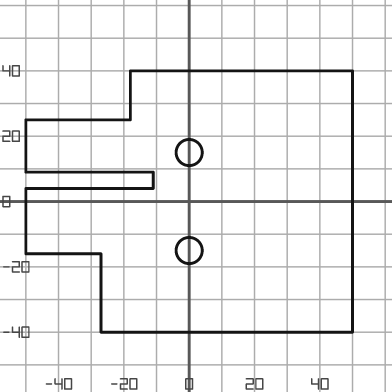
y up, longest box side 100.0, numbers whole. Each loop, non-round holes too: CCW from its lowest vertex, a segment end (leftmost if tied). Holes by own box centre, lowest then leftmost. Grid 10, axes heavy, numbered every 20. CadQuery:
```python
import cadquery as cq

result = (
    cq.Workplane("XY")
    .moveTo(-27.0, -40.0)
    .lineTo(50.0, -40.0)
    .lineTo(50.0, 40.0)
    .lineTo(-18.0, 40.0)
    .lineTo(-18.0, 25.0)
    .lineTo(-50.0, 25.0)
    .lineTo(-50.0, 9.0)
    .lineTo(-11.0, 9.0)
    .lineTo(-11.0, 4.0)
    .lineTo(-50.0, 4.0)
    .lineTo(-50.0, -16.0)
    .lineTo(-27.0, -16.0)
    .close()
    .moveTo(0.0, -15.0)
    .circle(4.0)
    .moveTo(0.0, 15.0)
    .circle(4.0)
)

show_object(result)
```